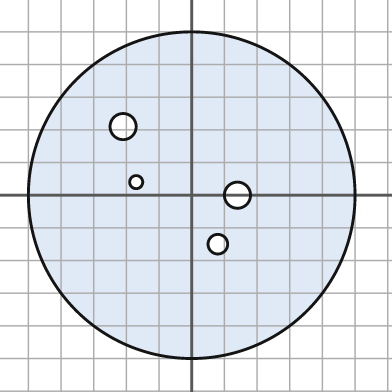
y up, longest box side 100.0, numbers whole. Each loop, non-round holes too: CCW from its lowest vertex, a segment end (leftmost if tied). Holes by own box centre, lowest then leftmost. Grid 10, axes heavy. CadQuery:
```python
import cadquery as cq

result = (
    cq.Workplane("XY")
    .moveTo(0.0, 0.0)
    .circle(50.0)
    .moveTo(8.0, -15.0)
    .circle(3.0)
    .moveTo(14.0, 0.0)
    .circle(4.0)
    .moveTo(-17.0, 4.0)
    .circle(2.0)
    .moveTo(-21.0, 21.0)
    .circle(4.0)
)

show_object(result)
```